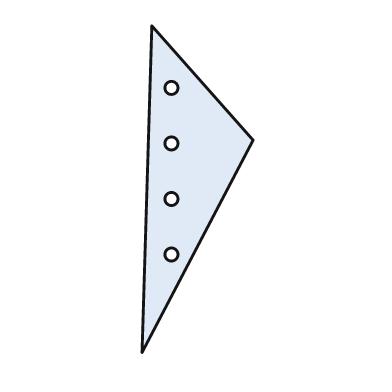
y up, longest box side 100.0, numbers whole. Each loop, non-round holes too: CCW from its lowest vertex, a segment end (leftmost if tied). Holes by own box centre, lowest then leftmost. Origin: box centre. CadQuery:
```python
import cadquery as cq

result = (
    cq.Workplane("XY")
    .moveTo(-17.0, -50.0)
    .lineTo(17.0, 15.0)
    .lineTo(-14.0, 50.0)
    .close()
    .moveTo(-8.0, -20.0)
    .circle(2.0)
    .moveTo(-8.0, -3.0)
    .circle(2.0)
    .moveTo(-8.0, 14.0)
    .circle(2.0)
    .moveTo(-8.0, 31.0)
    .circle(2.0)
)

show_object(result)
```